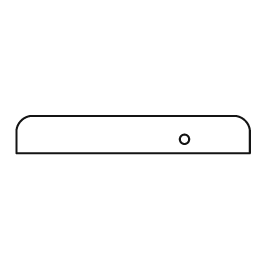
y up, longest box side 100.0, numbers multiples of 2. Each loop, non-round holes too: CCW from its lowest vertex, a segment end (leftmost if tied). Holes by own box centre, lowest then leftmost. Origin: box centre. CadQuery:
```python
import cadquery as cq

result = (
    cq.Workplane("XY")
    .moveTo(-50.0, -8.0)
    .lineTo(50.0, -8.0)
    .lineTo(50.0, 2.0)
    .threePointArc((48.0, 6.0), (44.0, 8.0))
    .lineTo(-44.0, 8.0)
    .threePointArc((-48.0, 6.0), (-50.0, 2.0))
    .close()
    .moveTo(22.0, -2.0)
    .circle(2.0)
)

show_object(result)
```